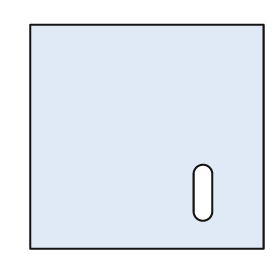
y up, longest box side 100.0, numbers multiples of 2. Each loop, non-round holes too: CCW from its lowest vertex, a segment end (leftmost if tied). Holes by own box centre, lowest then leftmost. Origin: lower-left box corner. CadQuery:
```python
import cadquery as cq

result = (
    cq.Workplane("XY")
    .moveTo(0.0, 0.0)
    .lineTo(100.0, 0.0)
    .lineTo(100.0, 96.0)
    .lineTo(0.0, 96.0)
    .close()
    .moveTo(70.0, 16.0)
    .threePointArc((74.0, 12.0), (78.0, 16.0))
    .lineTo(78.0, 32.0)
    .threePointArc((74.0, 36.0), (70.0, 32.0))
    .close()
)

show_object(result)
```